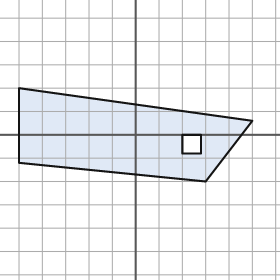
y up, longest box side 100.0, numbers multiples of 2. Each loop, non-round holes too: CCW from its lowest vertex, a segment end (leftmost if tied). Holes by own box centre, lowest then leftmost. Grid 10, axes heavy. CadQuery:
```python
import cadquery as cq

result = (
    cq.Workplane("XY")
    .moveTo(30.0, -20.0)
    .lineTo(50.0, 6.0)
    .lineTo(-50.0, 20.0)
    .lineTo(-50.0, -12.0)
    .close()
    .moveTo(20.0, -8.0)
    .lineTo(28.0, -8.0)
    .lineTo(28.0, 0.0)
    .lineTo(20.0, 0.0)
    .close()
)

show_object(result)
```